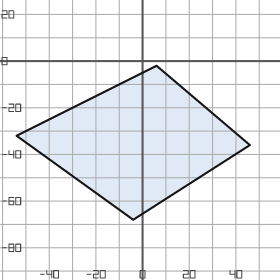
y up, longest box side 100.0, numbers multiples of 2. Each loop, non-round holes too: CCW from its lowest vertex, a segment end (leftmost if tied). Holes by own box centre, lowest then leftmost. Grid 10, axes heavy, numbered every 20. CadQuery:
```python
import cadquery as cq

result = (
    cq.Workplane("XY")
    .moveTo(-4.0, -68.0)
    .lineTo(46.0, -36.0)
    .lineTo(6.0, -2.0)
    .lineTo(-54.0, -32.0)
    .close()
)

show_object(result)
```